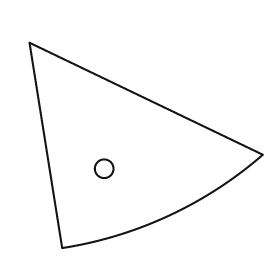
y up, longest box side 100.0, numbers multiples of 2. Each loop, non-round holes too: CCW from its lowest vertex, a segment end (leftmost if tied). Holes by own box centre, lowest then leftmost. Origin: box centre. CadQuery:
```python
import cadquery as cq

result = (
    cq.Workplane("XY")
    .moveTo(-36.0, -44.0)
    .threePointArc((10.0, -30.0), (50.0, -4.0))
    .lineTo(-50.0, 44.0)
    .close()
    .moveTo(-18.0, -10.0)
    .circle(4.0)
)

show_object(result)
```